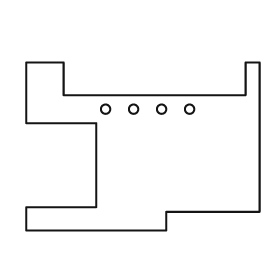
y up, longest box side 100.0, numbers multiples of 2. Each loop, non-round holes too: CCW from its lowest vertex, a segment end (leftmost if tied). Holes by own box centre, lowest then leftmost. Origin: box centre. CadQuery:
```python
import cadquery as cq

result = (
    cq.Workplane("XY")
    .moveTo(-50.0, -36.0)
    .lineTo(10.0, -36.0)
    .lineTo(10.0, -28.0)
    .lineTo(50.0, -28.0)
    .lineTo(50.0, 36.0)
    .lineTo(44.0, 36.0)
    .lineTo(44.0, 22.0)
    .lineTo(-34.0, 22.0)
    .lineTo(-34.0, 36.0)
    .lineTo(-50.0, 36.0)
    .lineTo(-50.0, 10.0)
    .lineTo(-20.0, 10.0)
    .lineTo(-20.0, -26.0)
    .lineTo(-50.0, -26.0)
    .close()
    .moveTo(-16.0, 16.0)
    .circle(2.0)
    .moveTo(-4.0, 16.0)
    .circle(2.0)
    .moveTo(8.0, 16.0)
    .circle(2.0)
    .moveTo(20.0, 16.0)
    .circle(2.0)
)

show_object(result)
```